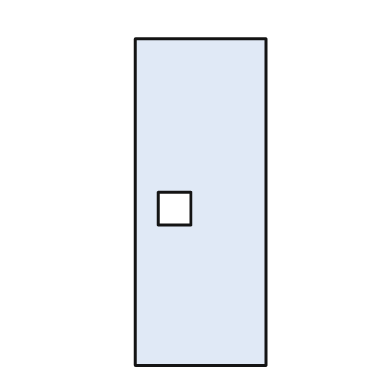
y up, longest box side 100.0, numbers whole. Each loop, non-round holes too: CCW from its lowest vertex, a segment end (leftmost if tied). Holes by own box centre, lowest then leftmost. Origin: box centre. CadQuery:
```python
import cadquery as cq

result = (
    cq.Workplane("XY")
    .moveTo(-20.0, -50.0)
    .lineTo(20.0, -50.0)
    .lineTo(20.0, 50.0)
    .lineTo(-20.0, 50.0)
    .close()
    .moveTo(-13.0, -7.0)
    .lineTo(-3.0, -7.0)
    .lineTo(-3.0, 3.0)
    .lineTo(-13.0, 3.0)
    .close()
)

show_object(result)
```